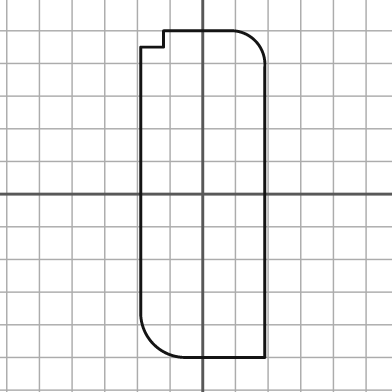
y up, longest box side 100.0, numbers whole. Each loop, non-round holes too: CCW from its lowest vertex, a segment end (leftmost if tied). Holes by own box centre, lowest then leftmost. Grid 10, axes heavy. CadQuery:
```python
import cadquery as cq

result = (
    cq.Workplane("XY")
    .moveTo(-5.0, -50.0)
    .lineTo(19.0, -50.0)
    .lineTo(19.0, 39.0)
    .threePointArc((16.0, 47.0), (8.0, 50.0))
    .lineTo(-12.0, 50.0)
    .lineTo(-12.0, 45.0)
    .lineTo(-19.0, 45.0)
    .lineTo(-19.0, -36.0)
    .threePointArc((-15.0, -46.0), (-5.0, -50.0))
    .close()
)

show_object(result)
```